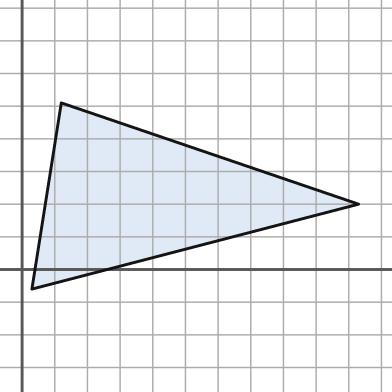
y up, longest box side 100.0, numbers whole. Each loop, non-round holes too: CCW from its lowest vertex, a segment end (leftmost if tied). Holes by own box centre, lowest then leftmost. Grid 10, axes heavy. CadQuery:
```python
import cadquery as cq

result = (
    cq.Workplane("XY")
    .moveTo(3.0, -6.0)
    .lineTo(103.0, 20.0)
    .lineTo(12.0, 51.0)
    .close()
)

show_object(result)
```